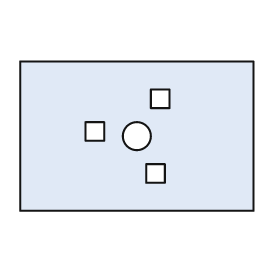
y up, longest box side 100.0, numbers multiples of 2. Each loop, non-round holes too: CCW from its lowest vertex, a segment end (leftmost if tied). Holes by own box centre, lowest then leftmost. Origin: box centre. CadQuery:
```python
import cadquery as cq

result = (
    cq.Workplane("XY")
    .moveTo(-50.0, -32.0)
    .lineTo(50.0, -32.0)
    .lineTo(50.0, 32.0)
    .lineTo(-50.0, 32.0)
    .close()
    .moveTo(4.0, -20.0)
    .lineTo(12.0, -20.0)
    .lineTo(12.0, -12.0)
    .lineTo(4.0, -12.0)
    .close()
    .moveTo(0.0, 0.0)
    .circle(6.0)
    .moveTo(-22.0, -2.0)
    .lineTo(-14.0, -2.0)
    .lineTo(-14.0, 6.0)
    .lineTo(-22.0, 6.0)
    .close()
    .moveTo(6.0, 12.0)
    .lineTo(14.0, 12.0)
    .lineTo(14.0, 20.0)
    .lineTo(6.0, 20.0)
    .close()
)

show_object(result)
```